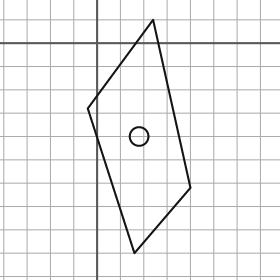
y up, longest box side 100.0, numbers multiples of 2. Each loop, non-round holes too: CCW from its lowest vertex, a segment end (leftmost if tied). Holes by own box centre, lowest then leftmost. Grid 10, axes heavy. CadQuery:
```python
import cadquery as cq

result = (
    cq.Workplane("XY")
    .moveTo(16.0, -90.0)
    .lineTo(40.0, -62.0)
    .lineTo(24.0, 10.0)
    .lineTo(-4.0, -28.0)
    .close()
    .moveTo(18.0, -40.0)
    .circle(4.0)
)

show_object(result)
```